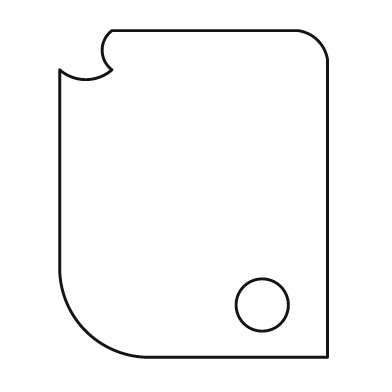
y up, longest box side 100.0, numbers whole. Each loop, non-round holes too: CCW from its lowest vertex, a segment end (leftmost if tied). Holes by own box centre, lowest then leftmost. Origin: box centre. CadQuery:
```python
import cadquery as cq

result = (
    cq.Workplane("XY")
    .moveTo(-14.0, -50.0)
    .lineTo(41.0, -50.0)
    .lineTo(41.0, 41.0)
    .threePointArc((38.0, 47.0), (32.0, 50.0))
    .lineTo(-25.0, 50.0)
    .threePointArc((-28.0, 44.0), (-25.0, 38.0))
    .threePointArc((-33.0, 35.0), (-41.0, 38.0))
    .lineTo(-41.0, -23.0)
    .threePointArc((-33.0, -42.0), (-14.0, -50.0))
    .close()
    .moveTo(21.0, -34.0)
    .circle(8.0)
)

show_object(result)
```